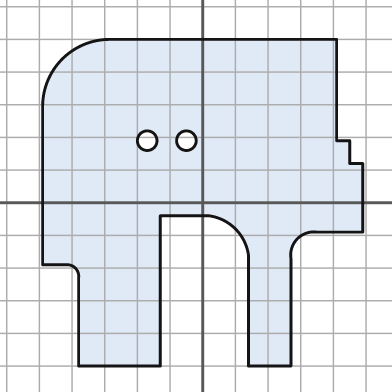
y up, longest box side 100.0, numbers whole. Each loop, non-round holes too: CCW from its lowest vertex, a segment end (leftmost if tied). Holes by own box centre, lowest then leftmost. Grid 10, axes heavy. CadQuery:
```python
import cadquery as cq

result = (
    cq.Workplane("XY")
    .moveTo(-38.0, -50.0)
    .lineTo(-13.0, -50.0)
    .lineTo(-13.0, -4.0)
    .lineTo(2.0, -4.0)
    .threePointArc((10.0, -8.0), (14.0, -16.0))
    .lineTo(14.0, -50.0)
    .lineTo(27.0, -50.0)
    .lineTo(27.0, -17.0)
    .threePointArc((29.0, -11.0), (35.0, -9.0))
    .lineTo(49.0, -9.0)
    .lineTo(49.0, 12.0)
    .lineTo(45.0, 12.0)
    .lineTo(45.0, 19.0)
    .lineTo(41.0, 19.0)
    .lineTo(41.0, 50.0)
    .lineTo(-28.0, 50.0)
    .threePointArc((-43.0, 44.0), (-49.0, 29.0))
    .lineTo(-49.0, -19.0)
    .lineTo(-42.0, -19.0)
    .threePointArc((-39.0, -20.0), (-38.0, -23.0))
    .close()
    .moveTo(-17.0, 19.0)
    .circle(3.0)
    .moveTo(-5.0, 19.0)
    .circle(3.0)
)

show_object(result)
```